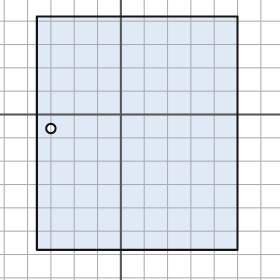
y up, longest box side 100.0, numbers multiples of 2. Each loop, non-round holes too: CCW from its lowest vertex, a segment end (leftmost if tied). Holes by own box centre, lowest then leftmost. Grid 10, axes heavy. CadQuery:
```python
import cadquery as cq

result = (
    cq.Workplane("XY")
    .moveTo(-36.0, -58.0)
    .lineTo(50.0, -58.0)
    .lineTo(50.0, 42.0)
    .lineTo(-36.0, 42.0)
    .close()
    .moveTo(-30.0, -6.0)
    .circle(2.0)
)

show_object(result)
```